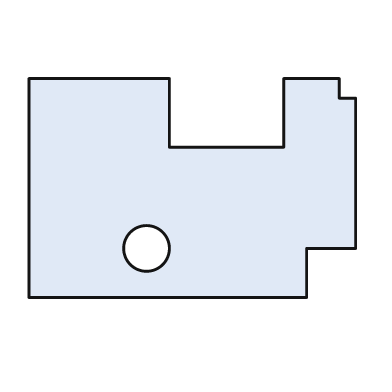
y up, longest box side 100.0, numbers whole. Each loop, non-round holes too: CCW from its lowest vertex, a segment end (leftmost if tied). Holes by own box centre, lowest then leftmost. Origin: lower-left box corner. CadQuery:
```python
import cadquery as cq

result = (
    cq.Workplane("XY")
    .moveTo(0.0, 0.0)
    .lineTo(85.0, 0.0)
    .lineTo(85.0, 15.0)
    .lineTo(100.0, 15.0)
    .lineTo(100.0, 61.0)
    .lineTo(95.0, 61.0)
    .lineTo(95.0, 67.0)
    .lineTo(78.0, 67.0)
    .lineTo(78.0, 46.0)
    .lineTo(43.0, 46.0)
    .lineTo(43.0, 67.0)
    .lineTo(0.0, 67.0)
    .close()
    .moveTo(36.0, 15.0)
    .circle(7.0)
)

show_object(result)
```